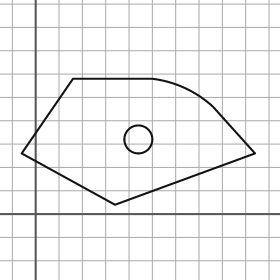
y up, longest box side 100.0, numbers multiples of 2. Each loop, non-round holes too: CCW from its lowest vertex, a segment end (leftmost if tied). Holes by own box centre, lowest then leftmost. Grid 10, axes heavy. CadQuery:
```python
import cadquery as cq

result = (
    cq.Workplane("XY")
    .moveTo(34.0, 4.0)
    .lineTo(94.0, 26.0)
    .lineTo(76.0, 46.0)
    .threePointArc((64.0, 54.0), (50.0, 58.0))
    .lineTo(16.0, 58.0)
    .lineTo(-6.0, 26.0)
    .close()
    .moveTo(44.0, 32.0)
    .circle(6.0)
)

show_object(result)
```